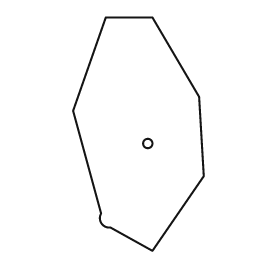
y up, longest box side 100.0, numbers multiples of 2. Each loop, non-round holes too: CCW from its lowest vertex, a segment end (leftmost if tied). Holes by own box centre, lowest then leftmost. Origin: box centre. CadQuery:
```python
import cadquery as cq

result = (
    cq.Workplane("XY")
    .moveTo(6.0, -50.0)
    .lineTo(28.0, -18.0)
    .lineTo(26.0, 16.0)
    .lineTo(6.0, 50.0)
    .lineTo(-14.0, 50.0)
    .lineTo(-28.0, 10.0)
    .lineTo(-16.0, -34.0)
    .threePointArc((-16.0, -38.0), (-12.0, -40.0))
    .close()
    .moveTo(4.0, -4.0)
    .circle(2.0)
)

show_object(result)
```